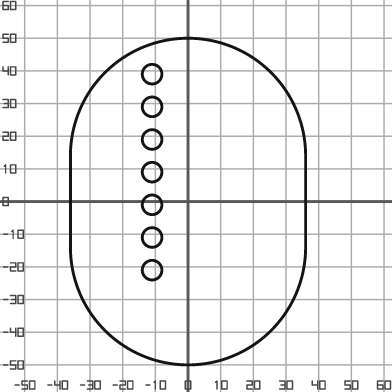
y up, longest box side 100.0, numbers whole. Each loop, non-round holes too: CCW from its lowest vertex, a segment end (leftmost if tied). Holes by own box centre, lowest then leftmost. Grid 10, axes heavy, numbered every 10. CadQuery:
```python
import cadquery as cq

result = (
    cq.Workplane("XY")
    .moveTo(-36.0, -14.0)
    .threePointArc((0.0, -50.0), (36.0, -14.0))
    .lineTo(36.0, 14.0)
    .threePointArc((0.0, 50.0), (-36.0, 14.0))
    .close()
    .moveTo(-11.0, -21.0)
    .circle(3.0)
    .moveTo(-11.0, -11.0)
    .circle(3.0)
    .moveTo(-11.0, -1.0)
    .circle(3.0)
    .moveTo(-11.0, 9.0)
    .circle(3.0)
    .moveTo(-11.0, 19.0)
    .circle(3.0)
    .moveTo(-11.0, 29.0)
    .circle(3.0)
    .moveTo(-11.0, 39.0)
    .circle(3.0)
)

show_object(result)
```